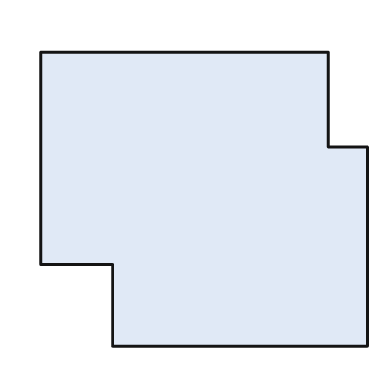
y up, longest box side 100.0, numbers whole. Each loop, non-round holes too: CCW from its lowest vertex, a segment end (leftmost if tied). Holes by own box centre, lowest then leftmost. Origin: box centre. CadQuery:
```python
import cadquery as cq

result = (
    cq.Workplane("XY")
    .moveTo(-28.0, -45.0)
    .lineTo(50.0, -45.0)
    .lineTo(50.0, 16.0)
    .lineTo(38.0, 16.0)
    .lineTo(38.0, 45.0)
    .lineTo(-50.0, 45.0)
    .lineTo(-50.0, -20.0)
    .lineTo(-28.0, -20.0)
    .close()
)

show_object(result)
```